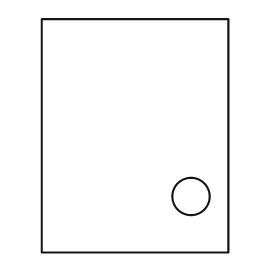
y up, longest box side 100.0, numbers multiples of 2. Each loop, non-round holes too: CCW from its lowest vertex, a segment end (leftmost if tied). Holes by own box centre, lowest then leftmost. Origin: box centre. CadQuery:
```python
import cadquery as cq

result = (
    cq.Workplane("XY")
    .moveTo(-40.0, -50.0)
    .lineTo(40.0, -50.0)
    .lineTo(40.0, 50.0)
    .lineTo(-40.0, 50.0)
    .close()
    .moveTo(24.0, -26.0)
    .circle(8.0)
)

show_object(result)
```